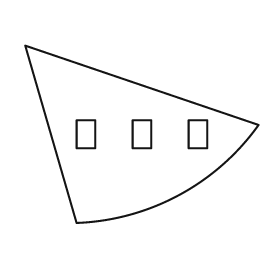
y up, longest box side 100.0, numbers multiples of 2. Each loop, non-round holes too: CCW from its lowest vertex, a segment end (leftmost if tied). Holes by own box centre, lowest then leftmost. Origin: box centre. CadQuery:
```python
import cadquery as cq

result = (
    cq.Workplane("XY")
    .moveTo(-28.0, -38.0)
    .threePointArc((16.0, -26.0), (50.0, 4.0))
    .lineTo(-50.0, 38.0)
    .close()
    .moveTo(-28.0, -6.0)
    .lineTo(-20.0, -6.0)
    .lineTo(-20.0, 6.0)
    .lineTo(-28.0, 6.0)
    .close()
    .moveTo(-4.0, -6.0)
    .lineTo(4.0, -6.0)
    .lineTo(4.0, 6.0)
    .lineTo(-4.0, 6.0)
    .close()
    .moveTo(20.0, -6.0)
    .lineTo(28.0, -6.0)
    .lineTo(28.0, 6.0)
    .lineTo(20.0, 6.0)
    .close()
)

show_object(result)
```